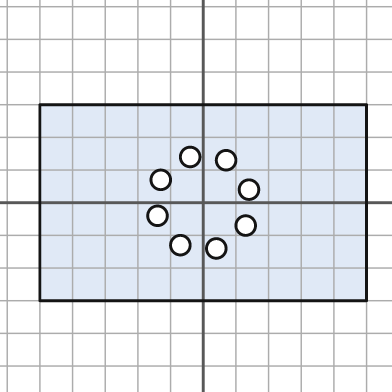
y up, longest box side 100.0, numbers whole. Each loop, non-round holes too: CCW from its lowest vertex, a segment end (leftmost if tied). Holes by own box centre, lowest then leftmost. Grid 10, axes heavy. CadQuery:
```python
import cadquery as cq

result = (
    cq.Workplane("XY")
    .moveTo(-50.0, -30.0)
    .lineTo(50.0, -30.0)
    .lineTo(50.0, 30.0)
    .lineTo(-50.0, 30.0)
    .close()
    .moveTo(4.0, -14.0)
    .circle(3.0)
    .moveTo(-7.0, -13.0)
    .circle(3.0)
    .moveTo(13.0, -7.0)
    .circle(3.0)
    .moveTo(-14.0, -4.0)
    .circle(3.0)
    .moveTo(14.0, 4.0)
    .circle(3.0)
    .moveTo(-13.0, 7.0)
    .circle(3.0)
    .moveTo(7.0, 13.0)
    .circle(3.0)
    .moveTo(-4.0, 14.0)
    .circle(3.0)
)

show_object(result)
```